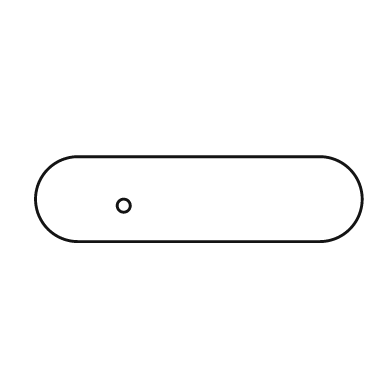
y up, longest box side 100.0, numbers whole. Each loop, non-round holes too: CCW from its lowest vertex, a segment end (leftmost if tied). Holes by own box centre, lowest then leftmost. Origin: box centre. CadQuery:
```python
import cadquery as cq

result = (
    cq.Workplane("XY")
    .moveTo(-37.0, -13.0)
    .lineTo(37.0, -13.0)
    .threePointArc((50.0, 0.0), (37.0, 13.0))
    .lineTo(-37.0, 13.0)
    .threePointArc((-50.0, 0.0), (-37.0, -13.0))
    .close()
    .moveTo(-23.0, -2.0)
    .circle(2.0)
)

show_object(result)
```